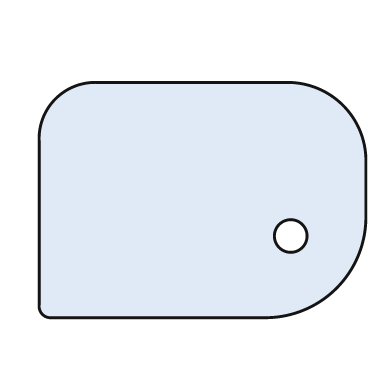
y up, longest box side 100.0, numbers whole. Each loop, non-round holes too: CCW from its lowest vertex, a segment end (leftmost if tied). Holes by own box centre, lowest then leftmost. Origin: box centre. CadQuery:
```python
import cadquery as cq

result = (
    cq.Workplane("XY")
    .moveTo(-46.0, -36.0)
    .lineTo(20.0, -36.0)
    .threePointArc((41.0, -27.0), (50.0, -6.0))
    .lineTo(50.0, 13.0)
    .threePointArc((43.0, 29.0), (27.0, 36.0))
    .lineTo(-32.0, 36.0)
    .threePointArc((-45.0, 31.0), (-50.0, 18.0))
    .lineTo(-50.0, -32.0)
    .threePointArc((-49.0, -35.0), (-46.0, -36.0))
    .close()
    .moveTo(27.0, -11.0)
    .circle(5.0)
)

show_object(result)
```